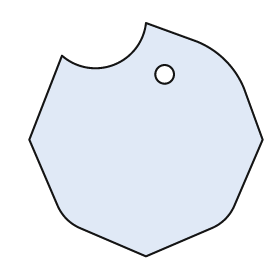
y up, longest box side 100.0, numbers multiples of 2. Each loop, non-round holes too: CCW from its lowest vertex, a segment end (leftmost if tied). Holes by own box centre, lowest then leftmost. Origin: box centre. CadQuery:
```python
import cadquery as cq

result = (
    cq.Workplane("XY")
    .moveTo(0.0, -50.0)
    .lineTo(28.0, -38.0)
    .threePointArc((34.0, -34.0), (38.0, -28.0))
    .lineTo(50.0, 0.0)
    .lineTo(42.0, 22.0)
    .threePointArc((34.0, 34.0), (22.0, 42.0))
    .lineTo(0.0, 50.0)
    .threePointArc((-14.0, 32.0), (-36.0, 36.0))
    .lineTo(-50.0, 0.0)
    .lineTo(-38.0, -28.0)
    .threePointArc((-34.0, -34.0), (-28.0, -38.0))
    .close()
    .moveTo(8.0, 28.0)
    .circle(4.0)
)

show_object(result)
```